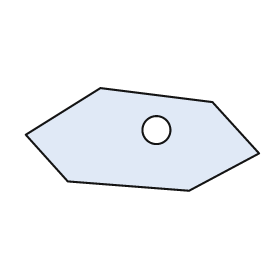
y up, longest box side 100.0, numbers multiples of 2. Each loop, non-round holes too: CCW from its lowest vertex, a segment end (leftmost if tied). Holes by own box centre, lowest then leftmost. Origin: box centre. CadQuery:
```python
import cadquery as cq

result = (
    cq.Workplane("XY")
    .moveTo(20.0, -22.0)
    .lineTo(50.0, -6.0)
    .lineTo(30.0, 16.0)
    .lineTo(-18.0, 22.0)
    .lineTo(-50.0, 2.0)
    .lineTo(-32.0, -18.0)
    .close()
    .moveTo(6.0, 4.0)
    .circle(6.0)
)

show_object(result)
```